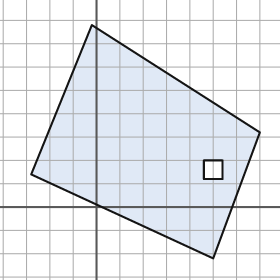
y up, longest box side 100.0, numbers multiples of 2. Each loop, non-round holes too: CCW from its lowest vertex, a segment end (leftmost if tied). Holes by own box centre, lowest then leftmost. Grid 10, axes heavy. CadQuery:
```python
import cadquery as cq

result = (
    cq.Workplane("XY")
    .moveTo(50.0, -22.0)
    .lineTo(70.0, 32.0)
    .lineTo(-2.0, 78.0)
    .lineTo(-28.0, 14.0)
    .close()
    .moveTo(46.0, 12.0)
    .lineTo(54.0, 12.0)
    .lineTo(54.0, 20.0)
    .lineTo(46.0, 20.0)
    .close()
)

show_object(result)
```